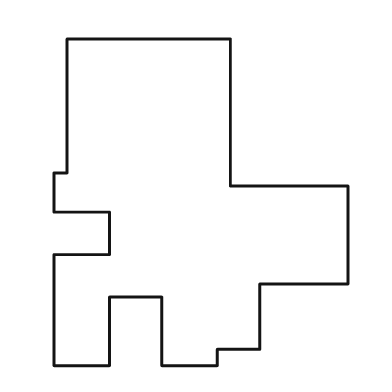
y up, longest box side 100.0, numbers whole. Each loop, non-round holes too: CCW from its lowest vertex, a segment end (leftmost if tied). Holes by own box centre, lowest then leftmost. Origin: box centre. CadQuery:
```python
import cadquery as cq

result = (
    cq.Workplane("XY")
    .moveTo(-45.0, -50.0)
    .lineTo(-28.0, -50.0)
    .lineTo(-28.0, -29.0)
    .lineTo(-12.0, -29.0)
    .lineTo(-12.0, -50.0)
    .lineTo(5.0, -50.0)
    .lineTo(5.0, -45.0)
    .lineTo(18.0, -45.0)
    .lineTo(18.0, -25.0)
    .lineTo(45.0, -25.0)
    .lineTo(45.0, 5.0)
    .lineTo(9.0, 5.0)
    .lineTo(9.0, 50.0)
    .lineTo(-41.0, 50.0)
    .lineTo(-41.0, 9.0)
    .lineTo(-45.0, 9.0)
    .lineTo(-45.0, -3.0)
    .lineTo(-28.0, -3.0)
    .lineTo(-28.0, -16.0)
    .lineTo(-45.0, -16.0)
    .close()
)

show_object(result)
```